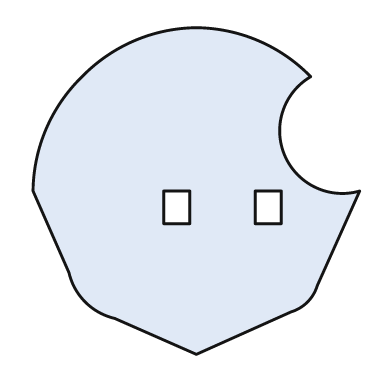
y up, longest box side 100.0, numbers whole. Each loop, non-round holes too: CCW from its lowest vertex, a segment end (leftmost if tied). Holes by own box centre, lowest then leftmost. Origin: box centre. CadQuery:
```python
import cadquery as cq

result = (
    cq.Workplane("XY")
    .moveTo(0.0, -50.0)
    .lineTo(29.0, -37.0)
    .threePointArc((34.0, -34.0), (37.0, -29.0))
    .lineTo(50.0, 0.0)
    .threePointArc((27.0, 11.0), (35.0, 35.0))
    .threePointArc((19.0, 46.0), (0.0, 50.0))
    .threePointArc((-19.0, 46.0), (-35.0, 35.0))
    .threePointArc((-46.0, 19.0), (-50.0, 0.0))
    .lineTo(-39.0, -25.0)
    .threePointArc((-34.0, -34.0), (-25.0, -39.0))
    .close()
    .moveTo(-10.0, -10.0)
    .lineTo(-2.0, -10.0)
    .lineTo(-2.0, 0.0)
    .lineTo(-10.0, 0.0)
    .close()
    .moveTo(18.0, -10.0)
    .lineTo(26.0, -10.0)
    .lineTo(26.0, 0.0)
    .lineTo(18.0, 0.0)
    .close()
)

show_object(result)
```